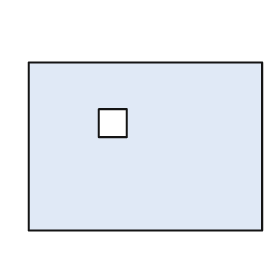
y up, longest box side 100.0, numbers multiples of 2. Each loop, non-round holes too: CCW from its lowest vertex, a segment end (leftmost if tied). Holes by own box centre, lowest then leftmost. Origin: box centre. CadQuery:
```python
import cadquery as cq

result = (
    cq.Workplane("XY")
    .moveTo(-50.0, -36.0)
    .lineTo(50.0, -36.0)
    .lineTo(50.0, 36.0)
    .lineTo(-50.0, 36.0)
    .close()
    .moveTo(-20.0, 4.0)
    .lineTo(-8.0, 4.0)
    .lineTo(-8.0, 16.0)
    .lineTo(-20.0, 16.0)
    .close()
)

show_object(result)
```